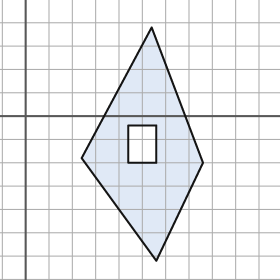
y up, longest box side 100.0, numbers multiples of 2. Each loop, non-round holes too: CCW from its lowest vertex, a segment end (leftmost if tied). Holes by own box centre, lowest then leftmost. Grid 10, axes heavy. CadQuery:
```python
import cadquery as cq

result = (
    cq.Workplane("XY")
    .moveTo(56.0, -62.0)
    .lineTo(76.0, -20.0)
    .lineTo(54.0, 38.0)
    .lineTo(24.0, -18.0)
    .close()
    .moveTo(44.0, -20.0)
    .lineTo(56.0, -20.0)
    .lineTo(56.0, -4.0)
    .lineTo(44.0, -4.0)
    .close()
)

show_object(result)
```